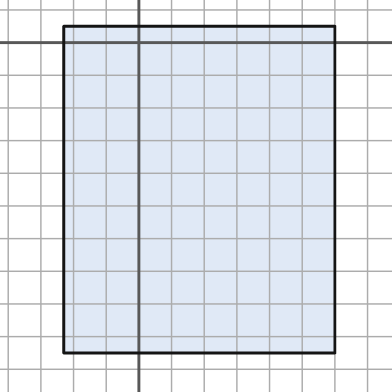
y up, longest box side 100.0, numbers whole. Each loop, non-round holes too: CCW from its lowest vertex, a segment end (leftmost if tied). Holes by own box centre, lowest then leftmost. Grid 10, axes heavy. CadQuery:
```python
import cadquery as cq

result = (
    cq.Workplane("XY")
    .moveTo(-23.0, -95.0)
    .lineTo(60.0, -95.0)
    .lineTo(60.0, 5.0)
    .lineTo(-23.0, 5.0)
    .close()
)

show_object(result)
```